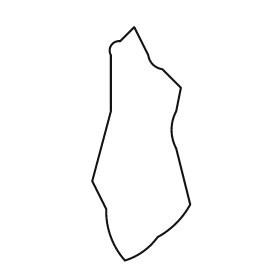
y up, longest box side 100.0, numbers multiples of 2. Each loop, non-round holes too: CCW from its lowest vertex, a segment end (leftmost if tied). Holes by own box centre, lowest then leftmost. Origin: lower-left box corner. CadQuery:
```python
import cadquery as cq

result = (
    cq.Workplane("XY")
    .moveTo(14.0, 0.0)
    .threePointArc((22.0, 4.0), (28.0, 10.0))
    .threePointArc((36.0, 16.0), (42.0, 24.0))
    .lineTo(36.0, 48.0)
    .threePointArc((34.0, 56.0), (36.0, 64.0))
    .lineTo(38.0, 74.0)
    .lineTo(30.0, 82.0)
    .threePointArc((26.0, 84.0), (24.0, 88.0))
    .lineTo(18.0, 100.0)
    .lineTo(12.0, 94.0)
    .threePointArc((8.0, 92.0), (8.0, 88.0))
    .lineTo(8.0, 64.0)
    .lineTo(0.0, 34.0)
    .lineTo(6.0, 22.0)
    .threePointArc((8.0, 10.0), (14.0, 0.0))
    .close()
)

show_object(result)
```